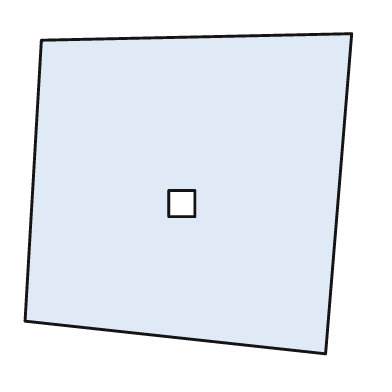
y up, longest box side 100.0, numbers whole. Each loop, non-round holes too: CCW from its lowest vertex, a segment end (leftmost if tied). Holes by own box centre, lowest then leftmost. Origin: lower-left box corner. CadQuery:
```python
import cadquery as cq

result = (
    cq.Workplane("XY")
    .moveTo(92.0, 0.0)
    .lineTo(100.0, 98.0)
    .lineTo(5.0, 96.0)
    .lineTo(0.0, 10.0)
    .close()
    .moveTo(44.0, 42.0)
    .lineTo(52.0, 42.0)
    .lineTo(52.0, 50.0)
    .lineTo(44.0, 50.0)
    .close()
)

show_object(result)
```